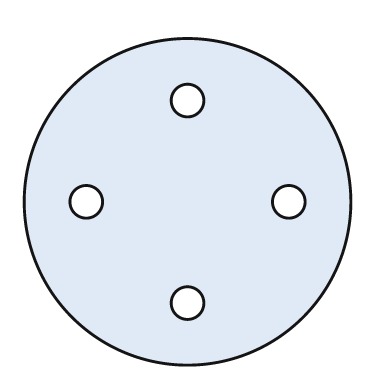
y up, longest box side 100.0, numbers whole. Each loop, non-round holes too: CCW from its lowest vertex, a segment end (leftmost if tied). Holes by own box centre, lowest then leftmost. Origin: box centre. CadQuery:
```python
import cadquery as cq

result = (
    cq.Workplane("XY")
    .moveTo(0.0, 0.0)
    .circle(50.0)
    .moveTo(0.0, -31.0)
    .circle(5.0)
    .moveTo(-31.0, 0.0)
    .circle(5.0)
    .moveTo(31.0, 0.0)
    .circle(5.0)
    .moveTo(0.0, 31.0)
    .circle(5.0)
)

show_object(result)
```